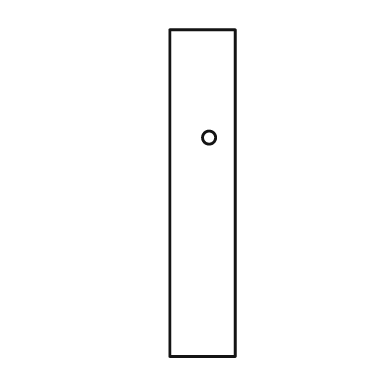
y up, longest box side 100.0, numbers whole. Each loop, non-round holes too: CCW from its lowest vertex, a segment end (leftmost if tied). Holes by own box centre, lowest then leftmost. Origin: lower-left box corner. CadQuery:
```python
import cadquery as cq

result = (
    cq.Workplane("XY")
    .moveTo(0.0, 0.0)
    .lineTo(20.0, 0.0)
    .lineTo(20.0, 100.0)
    .lineTo(0.0, 100.0)
    .close()
    .moveTo(12.0, 67.0)
    .circle(2.0)
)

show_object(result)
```